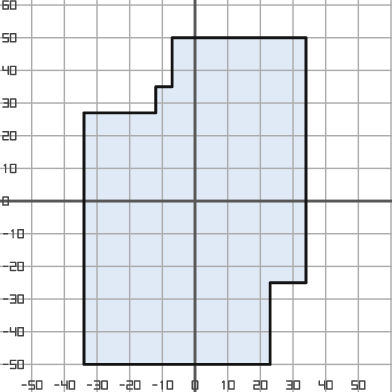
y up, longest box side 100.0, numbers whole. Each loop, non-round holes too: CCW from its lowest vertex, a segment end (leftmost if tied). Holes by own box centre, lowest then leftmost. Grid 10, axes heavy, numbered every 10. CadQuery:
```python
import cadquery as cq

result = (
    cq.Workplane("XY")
    .moveTo(-34.0, -50.0)
    .lineTo(23.0, -50.0)
    .lineTo(23.0, -25.0)
    .lineTo(34.0, -25.0)
    .lineTo(34.0, 50.0)
    .lineTo(-7.0, 50.0)
    .lineTo(-7.0, 35.0)
    .lineTo(-12.0, 35.0)
    .lineTo(-12.0, 27.0)
    .lineTo(-34.0, 27.0)
    .close()
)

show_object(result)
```